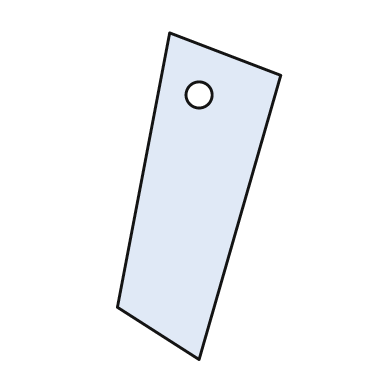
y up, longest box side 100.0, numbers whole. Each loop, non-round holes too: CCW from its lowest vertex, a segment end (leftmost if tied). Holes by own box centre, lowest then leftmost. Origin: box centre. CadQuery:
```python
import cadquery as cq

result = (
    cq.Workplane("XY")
    .moveTo(0.0, -50.0)
    .lineTo(25.0, 37.0)
    .lineTo(-9.0, 50.0)
    .lineTo(-25.0, -34.0)
    .close()
    .moveTo(0.0, 31.0)
    .circle(4.0)
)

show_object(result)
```